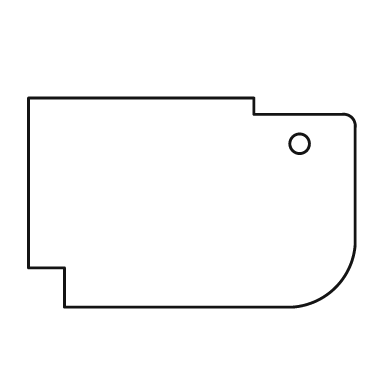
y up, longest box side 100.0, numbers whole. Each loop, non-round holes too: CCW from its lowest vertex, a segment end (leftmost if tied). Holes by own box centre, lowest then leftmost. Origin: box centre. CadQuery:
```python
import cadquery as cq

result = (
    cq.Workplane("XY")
    .moveTo(-39.0, -32.0)
    .lineTo(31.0, -32.0)
    .threePointArc((44.0, -26.0), (50.0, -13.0))
    .lineTo(50.0, 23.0)
    .threePointArc((49.0, 26.0), (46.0, 27.0))
    .lineTo(19.0, 27.0)
    .lineTo(19.0, 32.0)
    .lineTo(-50.0, 32.0)
    .lineTo(-50.0, -20.0)
    .lineTo(-39.0, -20.0)
    .close()
    .moveTo(33.0, 18.0)
    .circle(3.0)
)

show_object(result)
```